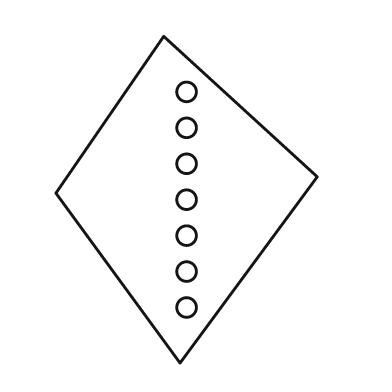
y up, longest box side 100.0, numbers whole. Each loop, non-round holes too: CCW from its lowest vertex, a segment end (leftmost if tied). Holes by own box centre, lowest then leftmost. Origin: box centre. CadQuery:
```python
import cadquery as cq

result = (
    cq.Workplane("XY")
    .moveTo(-2.0, -50.0)
    .lineTo(40.0, 7.0)
    .lineTo(-7.0, 50.0)
    .lineTo(-40.0, 2.0)
    .close()
    .moveTo(0.0, -33.0)
    .circle(3.0)
    .moveTo(0.0, -22.0)
    .circle(3.0)
    .moveTo(0.0, -11.0)
    .circle(3.0)
    .moveTo(0.0, 0.0)
    .circle(3.0)
    .moveTo(0.0, 11.0)
    .circle(3.0)
    .moveTo(0.0, 22.0)
    .circle(3.0)
    .moveTo(0.0, 33.0)
    .circle(3.0)
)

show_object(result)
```